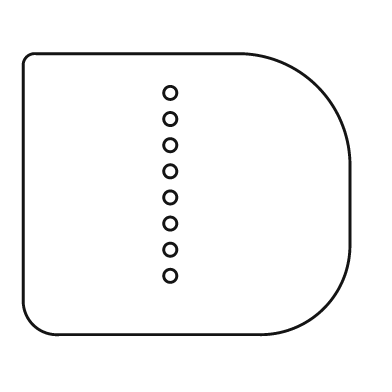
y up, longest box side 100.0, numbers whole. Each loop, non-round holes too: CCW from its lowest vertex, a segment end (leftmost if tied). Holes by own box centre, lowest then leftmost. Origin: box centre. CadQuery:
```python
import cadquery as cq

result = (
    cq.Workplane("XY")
    .moveTo(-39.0, -43.0)
    .lineTo(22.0, -43.0)
    .threePointArc((42.0, -35.0), (50.0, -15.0))
    .lineTo(50.0, 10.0)
    .threePointArc((40.0, 33.0), (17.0, 43.0))
    .lineTo(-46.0, 43.0)
    .threePointArc((-49.0, 42.0), (-50.0, 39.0))
    .lineTo(-50.0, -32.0)
    .threePointArc((-47.0, -40.0), (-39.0, -43.0))
    .close()
    .moveTo(-5.0, -25.0)
    .circle(2.0)
    .moveTo(-5.0, -17.0)
    .circle(2.0)
    .moveTo(-5.0, -9.0)
    .circle(2.0)
    .moveTo(-5.0, -1.0)
    .circle(2.0)
    .moveTo(-5.0, 7.0)
    .circle(2.0)
    .moveTo(-5.0, 15.0)
    .circle(2.0)
    .moveTo(-5.0, 23.0)
    .circle(2.0)
    .moveTo(-5.0, 31.0)
    .circle(2.0)
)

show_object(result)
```